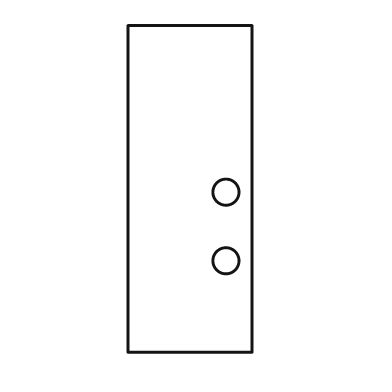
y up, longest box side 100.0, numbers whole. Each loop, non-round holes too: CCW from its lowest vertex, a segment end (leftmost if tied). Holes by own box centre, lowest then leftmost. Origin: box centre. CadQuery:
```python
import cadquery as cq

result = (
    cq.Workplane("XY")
    .moveTo(-19.0, -50.0)
    .lineTo(19.0, -50.0)
    .lineTo(19.0, 50.0)
    .lineTo(-19.0, 50.0)
    .close()
    .moveTo(11.0, -22.0)
    .circle(4.0)
    .moveTo(11.0, -1.0)
    .circle(4.0)
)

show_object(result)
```